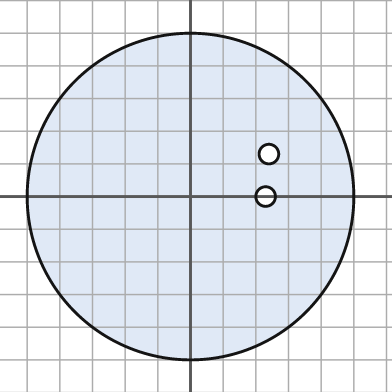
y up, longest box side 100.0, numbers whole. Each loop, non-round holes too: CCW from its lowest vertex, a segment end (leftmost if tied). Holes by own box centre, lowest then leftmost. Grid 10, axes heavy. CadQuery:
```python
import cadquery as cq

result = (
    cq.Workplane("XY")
    .moveTo(0.0, 0.0)
    .circle(50.0)
    .moveTo(23.0, 0.0)
    .circle(3.0)
    .moveTo(24.0, 13.0)
    .circle(3.0)
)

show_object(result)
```